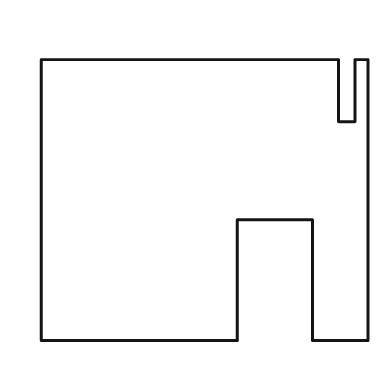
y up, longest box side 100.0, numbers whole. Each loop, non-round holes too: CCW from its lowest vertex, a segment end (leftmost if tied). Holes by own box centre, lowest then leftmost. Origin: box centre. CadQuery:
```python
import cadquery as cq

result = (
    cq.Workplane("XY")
    .moveTo(-50.0, -43.0)
    .lineTo(10.0, -43.0)
    .lineTo(10.0, -6.0)
    .lineTo(33.0, -6.0)
    .lineTo(33.0, -43.0)
    .lineTo(50.0, -43.0)
    .lineTo(50.0, 43.0)
    .lineTo(46.0, 43.0)
    .lineTo(46.0, 24.0)
    .lineTo(41.0, 24.0)
    .lineTo(41.0, 43.0)
    .lineTo(-50.0, 43.0)
    .close()
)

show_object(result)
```